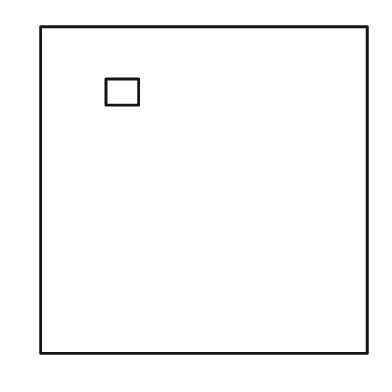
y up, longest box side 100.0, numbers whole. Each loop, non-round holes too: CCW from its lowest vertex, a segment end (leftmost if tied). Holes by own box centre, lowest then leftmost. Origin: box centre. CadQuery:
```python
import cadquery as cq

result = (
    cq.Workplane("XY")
    .moveTo(-50.0, -50.0)
    .lineTo(50.0, -50.0)
    .lineTo(50.0, 50.0)
    .lineTo(-50.0, 50.0)
    .close()
    .moveTo(-30.0, 26.0)
    .lineTo(-20.0, 26.0)
    .lineTo(-20.0, 34.0)
    .lineTo(-30.0, 34.0)
    .close()
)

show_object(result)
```